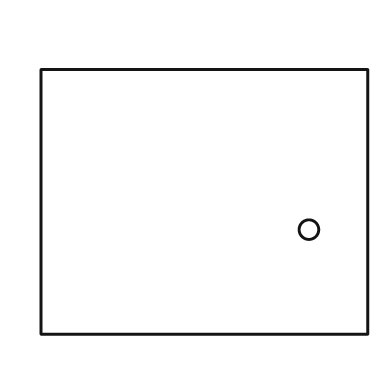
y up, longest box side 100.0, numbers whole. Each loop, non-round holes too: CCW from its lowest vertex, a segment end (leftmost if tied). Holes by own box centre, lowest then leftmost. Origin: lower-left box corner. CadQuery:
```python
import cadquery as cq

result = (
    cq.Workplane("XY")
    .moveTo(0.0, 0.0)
    .lineTo(100.0, 0.0)
    .lineTo(100.0, 81.0)
    .lineTo(0.0, 81.0)
    .close()
    .moveTo(82.0, 32.0)
    .circle(3.0)
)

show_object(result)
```